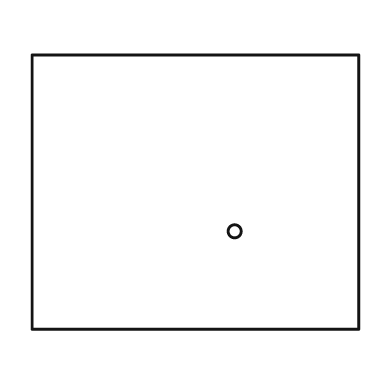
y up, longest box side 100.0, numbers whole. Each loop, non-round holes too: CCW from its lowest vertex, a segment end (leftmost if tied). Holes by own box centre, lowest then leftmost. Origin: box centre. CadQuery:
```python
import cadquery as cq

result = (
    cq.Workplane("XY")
    .moveTo(-50.0, -42.0)
    .lineTo(50.0, -42.0)
    .lineTo(50.0, 42.0)
    .lineTo(-50.0, 42.0)
    .close()
    .moveTo(12.0, -12.0)
    .circle(2.0)
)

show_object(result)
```